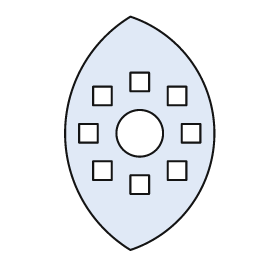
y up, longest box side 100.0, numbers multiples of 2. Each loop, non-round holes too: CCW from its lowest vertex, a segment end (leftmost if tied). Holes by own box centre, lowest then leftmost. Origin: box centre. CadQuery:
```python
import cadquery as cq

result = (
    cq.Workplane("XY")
    .moveTo(-4.0, -50.0)
    .threePointArc((32.0, 0.0), (-4.0, 50.0))
    .threePointArc((-32.0, 0.0), (-4.0, -50.0))
    .close()
    .moveTo(-4.0, -26.0)
    .lineTo(4.0, -26.0)
    .lineTo(4.0, -18.0)
    .lineTo(-4.0, -18.0)
    .close()
    .moveTo(-20.0, -20.0)
    .lineTo(-12.0, -20.0)
    .lineTo(-12.0, -12.0)
    .lineTo(-20.0, -12.0)
    .close()
    .moveTo(12.0, -20.0)
    .lineTo(20.0, -20.0)
    .lineTo(20.0, -12.0)
    .lineTo(12.0, -12.0)
    .close()
    .moveTo(-26.0, -4.0)
    .lineTo(-18.0, -4.0)
    .lineTo(-18.0, 4.0)
    .lineTo(-26.0, 4.0)
    .close()
    .moveTo(0.0, 0.0)
    .circle(10.0)
    .moveTo(18.0, -4.0)
    .lineTo(26.0, -4.0)
    .lineTo(26.0, 4.0)
    .lineTo(18.0, 4.0)
    .close()
    .moveTo(-20.0, 12.0)
    .lineTo(-12.0, 12.0)
    .lineTo(-12.0, 20.0)
    .lineTo(-20.0, 20.0)
    .close()
    .moveTo(12.0, 12.0)
    .lineTo(20.0, 12.0)
    .lineTo(20.0, 20.0)
    .lineTo(12.0, 20.0)
    .close()
    .moveTo(-4.0, 18.0)
    .lineTo(4.0, 18.0)
    .lineTo(4.0, 26.0)
    .lineTo(-4.0, 26.0)
    .close()
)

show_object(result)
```